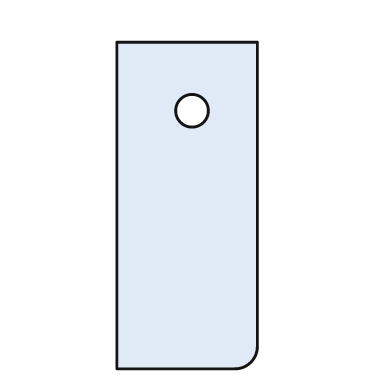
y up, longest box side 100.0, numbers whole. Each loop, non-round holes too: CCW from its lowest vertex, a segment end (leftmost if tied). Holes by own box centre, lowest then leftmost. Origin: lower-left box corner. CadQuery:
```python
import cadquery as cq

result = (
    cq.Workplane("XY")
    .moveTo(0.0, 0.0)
    .lineTo(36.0, 0.0)
    .threePointArc((41.0, 2.0), (43.0, 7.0))
    .lineTo(43.0, 100.0)
    .lineTo(0.0, 100.0)
    .close()
    .moveTo(23.0, 79.0)
    .circle(5.0)
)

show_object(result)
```